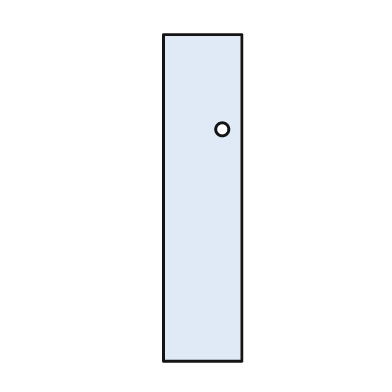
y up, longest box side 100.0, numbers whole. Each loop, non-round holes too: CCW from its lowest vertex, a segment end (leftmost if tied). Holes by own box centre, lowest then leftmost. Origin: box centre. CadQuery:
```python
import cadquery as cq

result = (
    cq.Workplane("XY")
    .moveTo(-12.0, -50.0)
    .lineTo(12.0, -50.0)
    .lineTo(12.0, 50.0)
    .lineTo(-12.0, 50.0)
    .close()
    .moveTo(6.0, 21.0)
    .circle(2.0)
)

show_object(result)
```